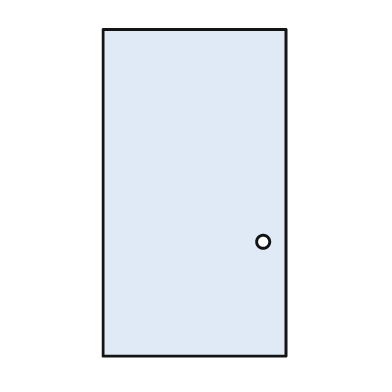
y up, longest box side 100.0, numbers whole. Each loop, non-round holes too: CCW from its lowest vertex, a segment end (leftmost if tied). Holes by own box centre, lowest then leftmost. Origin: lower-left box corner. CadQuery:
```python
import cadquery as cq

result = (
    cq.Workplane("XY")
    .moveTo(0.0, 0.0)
    .lineTo(56.0, 0.0)
    .lineTo(56.0, 100.0)
    .lineTo(0.0, 100.0)
    .close()
    .moveTo(49.0, 35.0)
    .circle(2.0)
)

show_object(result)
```